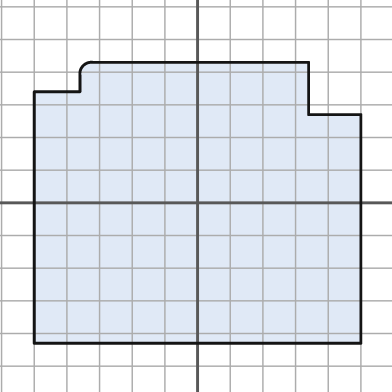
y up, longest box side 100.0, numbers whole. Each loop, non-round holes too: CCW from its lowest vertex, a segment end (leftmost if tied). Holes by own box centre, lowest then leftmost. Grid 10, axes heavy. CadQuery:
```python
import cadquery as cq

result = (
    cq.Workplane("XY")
    .moveTo(-50.0, -43.0)
    .lineTo(50.0, -43.0)
    .lineTo(50.0, 27.0)
    .lineTo(34.0, 27.0)
    .lineTo(34.0, 43.0)
    .lineTo(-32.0, 43.0)
    .threePointArc((-35.0, 42.0), (-36.0, 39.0))
    .lineTo(-36.0, 34.0)
    .lineTo(-50.0, 34.0)
    .close()
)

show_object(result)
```